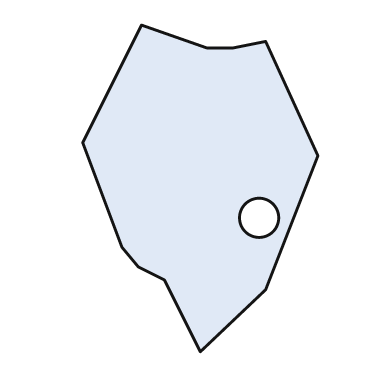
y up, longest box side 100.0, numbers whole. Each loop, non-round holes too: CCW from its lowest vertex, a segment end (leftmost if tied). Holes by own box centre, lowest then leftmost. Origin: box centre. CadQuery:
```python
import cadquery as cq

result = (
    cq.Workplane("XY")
    .moveTo(0.0, -50.0)
    .lineTo(20.0, -31.0)
    .lineTo(36.0, 10.0)
    .lineTo(20.0, 45.0)
    .lineTo(10.0, 43.0)
    .lineTo(2.0, 43.0)
    .lineTo(-18.0, 50.0)
    .lineTo(-36.0, 14.0)
    .lineTo(-24.0, -18.0)
    .lineTo(-19.0, -24.0)
    .lineTo(-11.0, -28.0)
    .close()
    .moveTo(18.0, -9.0)
    .circle(6.0)
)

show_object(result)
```